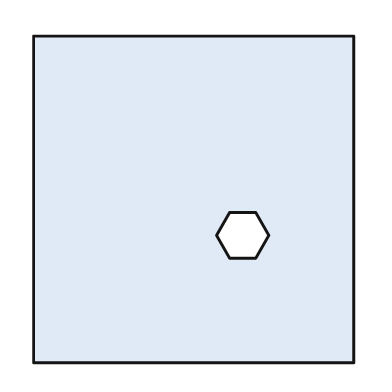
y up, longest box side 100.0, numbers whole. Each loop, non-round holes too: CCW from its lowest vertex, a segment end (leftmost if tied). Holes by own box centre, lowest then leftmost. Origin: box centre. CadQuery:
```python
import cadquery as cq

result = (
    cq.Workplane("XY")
    .moveTo(-49.0, -50.0)
    .lineTo(49.0, -50.0)
    .lineTo(49.0, 50.0)
    .lineTo(-49.0, 50.0)
    .close()
    .moveTo(11.0, -18.0)
    .lineTo(19.0, -18.0)
    .lineTo(23.0, -11.0)
    .lineTo(19.0, -4.0)
    .lineTo(11.0, -4.0)
    .lineTo(7.0, -11.0)
    .close()
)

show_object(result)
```